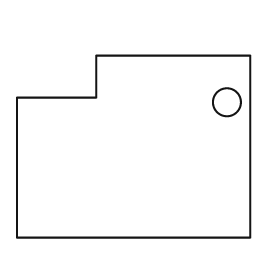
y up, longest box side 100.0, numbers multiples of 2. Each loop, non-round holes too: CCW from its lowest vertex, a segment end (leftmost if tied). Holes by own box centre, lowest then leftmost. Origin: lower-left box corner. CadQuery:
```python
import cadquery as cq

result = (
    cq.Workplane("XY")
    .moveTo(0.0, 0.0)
    .lineTo(100.0, 0.0)
    .lineTo(100.0, 78.0)
    .lineTo(34.0, 78.0)
    .lineTo(34.0, 60.0)
    .lineTo(0.0, 60.0)
    .close()
    .moveTo(90.0, 58.0)
    .circle(6.0)
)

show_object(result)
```